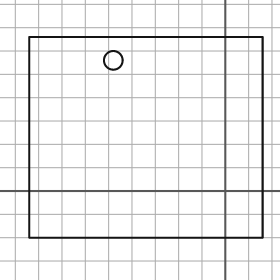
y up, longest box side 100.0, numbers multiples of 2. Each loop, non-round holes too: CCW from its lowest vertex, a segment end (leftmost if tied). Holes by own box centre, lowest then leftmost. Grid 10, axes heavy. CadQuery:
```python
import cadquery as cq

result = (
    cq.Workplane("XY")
    .moveTo(-84.0, -20.0)
    .lineTo(16.0, -20.0)
    .lineTo(16.0, 66.0)
    .lineTo(-84.0, 66.0)
    .close()
    .moveTo(-48.0, 56.0)
    .circle(4.0)
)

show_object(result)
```